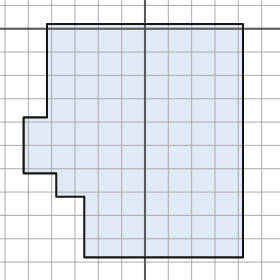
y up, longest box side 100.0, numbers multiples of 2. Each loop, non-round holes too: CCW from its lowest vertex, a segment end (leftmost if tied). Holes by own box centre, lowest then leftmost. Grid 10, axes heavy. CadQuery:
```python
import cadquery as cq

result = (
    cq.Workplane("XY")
    .moveTo(-26.0, -98.0)
    .lineTo(42.0, -98.0)
    .lineTo(42.0, 2.0)
    .lineTo(-42.0, 2.0)
    .lineTo(-42.0, -38.0)
    .lineTo(-52.0, -38.0)
    .lineTo(-52.0, -62.0)
    .lineTo(-38.0, -62.0)
    .lineTo(-38.0, -72.0)
    .lineTo(-26.0, -72.0)
    .close()
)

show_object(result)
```